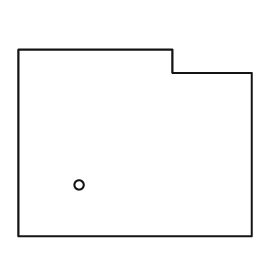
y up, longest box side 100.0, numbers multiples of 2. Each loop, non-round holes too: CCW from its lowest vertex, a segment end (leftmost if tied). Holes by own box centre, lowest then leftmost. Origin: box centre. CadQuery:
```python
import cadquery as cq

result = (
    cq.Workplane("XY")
    .moveTo(-50.0, -40.0)
    .lineTo(50.0, -40.0)
    .lineTo(50.0, 30.0)
    .lineTo(16.0, 30.0)
    .lineTo(16.0, 40.0)
    .lineTo(-50.0, 40.0)
    .close()
    .moveTo(-24.0, -18.0)
    .circle(2.0)
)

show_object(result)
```